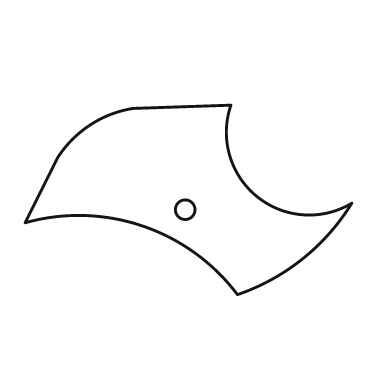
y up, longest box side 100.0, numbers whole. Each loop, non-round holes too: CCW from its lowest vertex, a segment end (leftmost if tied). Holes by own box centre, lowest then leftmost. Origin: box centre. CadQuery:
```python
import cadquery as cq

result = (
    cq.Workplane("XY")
    .moveTo(15.0, -29.0)
    .threePointArc((35.0, -18.0), (50.0, -1.0))
    .threePointArc((21.0, 1.0), (13.0, 29.0))
    .lineTo(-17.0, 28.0)
    .threePointArc((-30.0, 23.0), (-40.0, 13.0))
    .lineTo(-50.0, -7.0)
    .threePointArc((-14.0, -8.0), (15.0, -29.0))
    .close()
    .moveTo(-1.0, -3.0)
    .circle(3.0)
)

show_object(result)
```